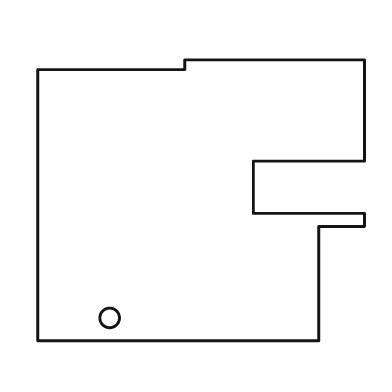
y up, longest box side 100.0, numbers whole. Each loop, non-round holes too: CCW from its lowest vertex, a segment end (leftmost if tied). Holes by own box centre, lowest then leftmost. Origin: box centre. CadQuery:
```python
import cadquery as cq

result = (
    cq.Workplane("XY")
    .moveTo(-50.0, -43.0)
    .lineTo(36.0, -43.0)
    .lineTo(36.0, -8.0)
    .lineTo(50.0, -8.0)
    .lineTo(50.0, -4.0)
    .lineTo(16.0, -4.0)
    .lineTo(16.0, 12.0)
    .lineTo(50.0, 12.0)
    .lineTo(50.0, 43.0)
    .lineTo(-5.0, 43.0)
    .lineTo(-5.0, 40.0)
    .lineTo(-50.0, 40.0)
    .close()
    .moveTo(-28.0, -36.0)
    .circle(3.0)
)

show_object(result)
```